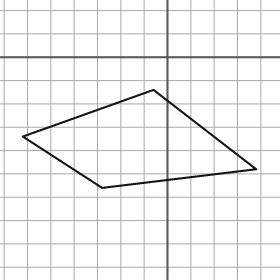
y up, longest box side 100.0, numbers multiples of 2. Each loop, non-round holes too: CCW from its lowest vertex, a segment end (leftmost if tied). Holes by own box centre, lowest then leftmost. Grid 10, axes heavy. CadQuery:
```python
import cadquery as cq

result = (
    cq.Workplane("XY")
    .moveTo(-28.0, -56.0)
    .lineTo(38.0, -48.0)
    .lineTo(-6.0, -14.0)
    .lineTo(-62.0, -34.0)
    .close()
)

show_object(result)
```